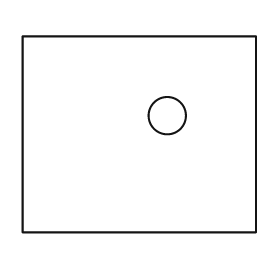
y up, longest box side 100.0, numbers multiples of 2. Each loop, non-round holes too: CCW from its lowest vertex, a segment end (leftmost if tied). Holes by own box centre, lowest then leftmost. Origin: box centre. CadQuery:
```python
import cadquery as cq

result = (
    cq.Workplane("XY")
    .moveTo(-50.0, -42.0)
    .lineTo(50.0, -42.0)
    .lineTo(50.0, 42.0)
    .lineTo(-50.0, 42.0)
    .close()
    .moveTo(12.0, 8.0)
    .circle(8.0)
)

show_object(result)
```